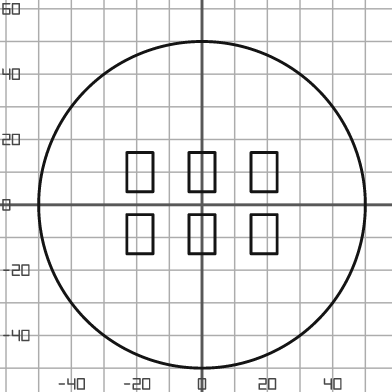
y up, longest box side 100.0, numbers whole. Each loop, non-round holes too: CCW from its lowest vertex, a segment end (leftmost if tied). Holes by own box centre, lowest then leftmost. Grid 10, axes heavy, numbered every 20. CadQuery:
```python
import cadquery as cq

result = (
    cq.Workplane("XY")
    .moveTo(0.0, 0.0)
    .circle(50.0)
    .moveTo(-23.0, -15.0)
    .lineTo(-15.0, -15.0)
    .lineTo(-15.0, -3.0)
    .lineTo(-23.0, -3.0)
    .close()
    .moveTo(-4.0, -15.0)
    .lineTo(4.0, -15.0)
    .lineTo(4.0, -3.0)
    .lineTo(-4.0, -3.0)
    .close()
    .moveTo(15.0, -15.0)
    .lineTo(23.0, -15.0)
    .lineTo(23.0, -3.0)
    .lineTo(15.0, -3.0)
    .close()
    .moveTo(-23.0, 4.0)
    .lineTo(-15.0, 4.0)
    .lineTo(-15.0, 16.0)
    .lineTo(-23.0, 16.0)
    .close()
    .moveTo(-4.0, 4.0)
    .lineTo(4.0, 4.0)
    .lineTo(4.0, 16.0)
    .lineTo(-4.0, 16.0)
    .close()
    .moveTo(15.0, 4.0)
    .lineTo(23.0, 4.0)
    .lineTo(23.0, 16.0)
    .lineTo(15.0, 16.0)
    .close()
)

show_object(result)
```